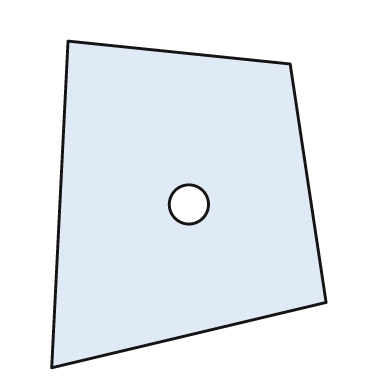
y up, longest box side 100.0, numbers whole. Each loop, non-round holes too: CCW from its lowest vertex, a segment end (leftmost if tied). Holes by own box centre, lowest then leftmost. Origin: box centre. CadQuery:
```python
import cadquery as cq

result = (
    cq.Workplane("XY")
    .moveTo(-42.0, -50.0)
    .lineTo(42.0, -30.0)
    .lineTo(31.0, 43.0)
    .lineTo(-37.0, 50.0)
    .close()
    .moveTo(0.0, 0.0)
    .circle(6.0)
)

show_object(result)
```